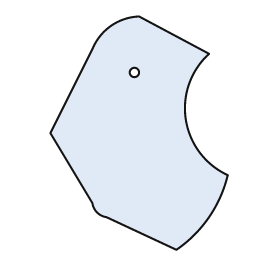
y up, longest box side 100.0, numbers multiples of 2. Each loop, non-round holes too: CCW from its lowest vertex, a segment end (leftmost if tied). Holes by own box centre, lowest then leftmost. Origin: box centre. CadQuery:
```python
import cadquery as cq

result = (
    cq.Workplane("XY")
    .moveTo(16.0, -50.0)
    .threePointArc((30.0, -36.0), (38.0, -18.0))
    .threePointArc((20.0, 6.0), (30.0, 34.0))
    .lineTo(0.0, 50.0)
    .threePointArc((-12.0, 46.0), (-20.0, 36.0))
    .lineTo(-38.0, 0.0)
    .lineTo(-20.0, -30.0)
    .threePointArc((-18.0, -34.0), (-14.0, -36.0))
    .close()
    .moveTo(-2.0, 26.0)
    .circle(2.0)
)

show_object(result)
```